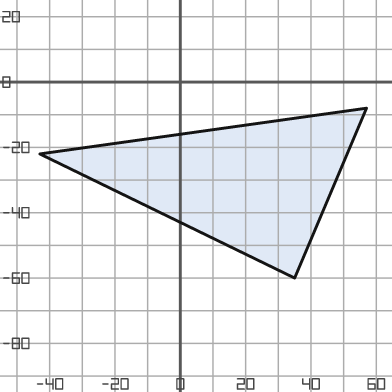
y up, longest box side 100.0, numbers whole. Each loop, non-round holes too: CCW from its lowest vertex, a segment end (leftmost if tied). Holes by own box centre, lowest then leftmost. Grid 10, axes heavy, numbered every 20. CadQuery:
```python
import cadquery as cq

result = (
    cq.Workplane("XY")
    .moveTo(35.0, -60.0)
    .lineTo(57.0, -8.0)
    .lineTo(-43.0, -22.0)
    .close()
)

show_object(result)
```